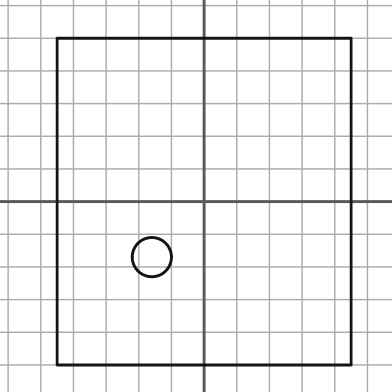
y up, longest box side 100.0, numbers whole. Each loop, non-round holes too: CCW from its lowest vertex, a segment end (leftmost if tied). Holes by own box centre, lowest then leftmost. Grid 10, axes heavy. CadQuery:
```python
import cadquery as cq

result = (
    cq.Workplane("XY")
    .moveTo(-45.0, -50.0)
    .lineTo(45.0, -50.0)
    .lineTo(45.0, 50.0)
    .lineTo(-45.0, 50.0)
    .close()
    .moveTo(-16.0, -17.0)
    .circle(6.0)
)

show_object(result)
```